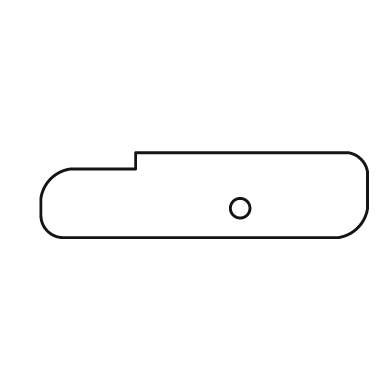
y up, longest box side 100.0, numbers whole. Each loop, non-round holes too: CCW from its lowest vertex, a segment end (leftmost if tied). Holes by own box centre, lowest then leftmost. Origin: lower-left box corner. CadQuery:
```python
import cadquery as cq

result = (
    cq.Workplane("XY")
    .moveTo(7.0, 0.0)
    .lineTo(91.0, 0.0)
    .threePointArc((97.0, 3.0), (100.0, 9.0))
    .lineTo(100.0, 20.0)
    .threePointArc((98.0, 24.0), (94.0, 26.0))
    .lineTo(29.0, 26.0)
    .lineTo(29.0, 21.0)
    .lineTo(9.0, 21.0)
    .threePointArc((3.0, 18.0), (0.0, 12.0))
    .lineTo(0.0, 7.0)
    .threePointArc((2.0, 2.0), (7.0, 0.0))
    .close()
    .moveTo(61.0, 9.0)
    .circle(3.0)
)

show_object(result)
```